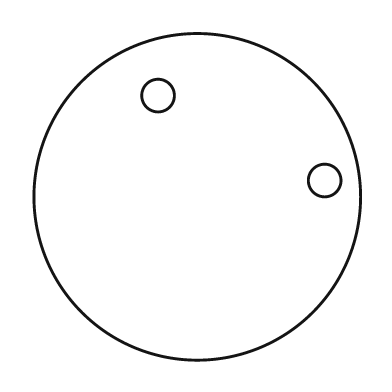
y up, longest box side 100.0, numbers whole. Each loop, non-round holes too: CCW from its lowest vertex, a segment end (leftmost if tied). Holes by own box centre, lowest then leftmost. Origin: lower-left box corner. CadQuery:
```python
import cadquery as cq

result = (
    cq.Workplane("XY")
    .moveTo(50.0, 50.0)
    .circle(50.0)
    .moveTo(89.0, 55.0)
    .circle(5.0)
    .moveTo(38.0, 81.0)
    .circle(5.0)
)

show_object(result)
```